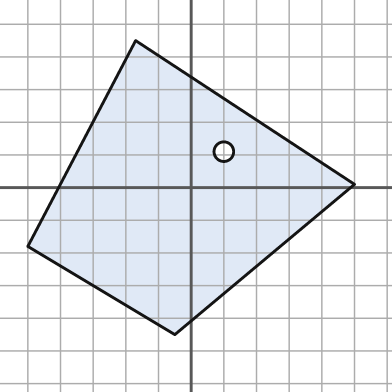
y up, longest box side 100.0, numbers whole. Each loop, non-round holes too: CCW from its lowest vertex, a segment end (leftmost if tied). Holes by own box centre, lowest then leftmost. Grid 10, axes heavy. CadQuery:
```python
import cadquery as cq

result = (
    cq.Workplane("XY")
    .moveTo(-5.0, -45.0)
    .lineTo(50.0, 1.0)
    .lineTo(-17.0, 45.0)
    .lineTo(-50.0, -18.0)
    .close()
    .moveTo(10.0, 11.0)
    .circle(3.0)
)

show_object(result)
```